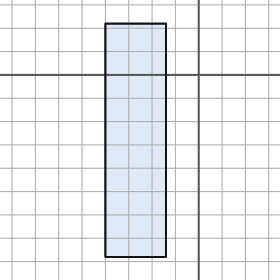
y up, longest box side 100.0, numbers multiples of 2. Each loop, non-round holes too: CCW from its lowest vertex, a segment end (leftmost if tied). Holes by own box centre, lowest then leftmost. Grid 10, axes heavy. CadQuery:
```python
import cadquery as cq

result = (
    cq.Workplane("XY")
    .moveTo(-40.0, -78.0)
    .lineTo(-14.0, -78.0)
    .lineTo(-14.0, 22.0)
    .lineTo(-40.0, 22.0)
    .close()
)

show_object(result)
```